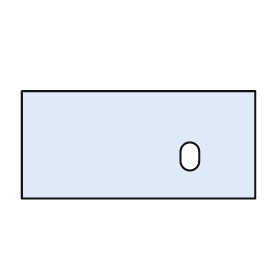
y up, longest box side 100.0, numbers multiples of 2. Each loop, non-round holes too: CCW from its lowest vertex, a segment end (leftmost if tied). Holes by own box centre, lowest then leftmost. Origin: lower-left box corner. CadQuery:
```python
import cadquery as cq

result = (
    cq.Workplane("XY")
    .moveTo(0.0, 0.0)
    .lineTo(100.0, 0.0)
    .lineTo(100.0, 46.0)
    .lineTo(0.0, 46.0)
    .close()
    .moveTo(68.0, 16.0)
    .threePointArc((72.0, 12.0), (76.0, 16.0))
    .lineTo(76.0, 20.0)
    .threePointArc((72.0, 24.0), (68.0, 20.0))
    .close()
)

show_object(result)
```